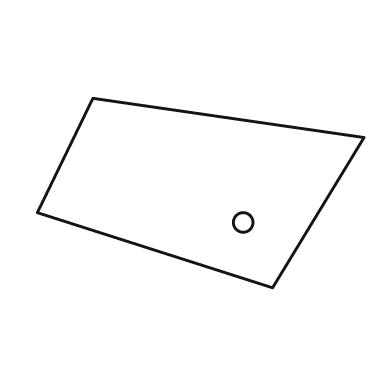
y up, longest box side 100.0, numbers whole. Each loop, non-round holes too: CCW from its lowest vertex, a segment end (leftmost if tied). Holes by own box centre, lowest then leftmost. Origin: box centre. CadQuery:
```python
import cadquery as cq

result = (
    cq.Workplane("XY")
    .moveTo(22.0, -29.0)
    .lineTo(50.0, 17.0)
    .lineTo(-33.0, 29.0)
    .lineTo(-50.0, -6.0)
    .close()
    .moveTo(13.0, -9.0)
    .circle(3.0)
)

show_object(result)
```